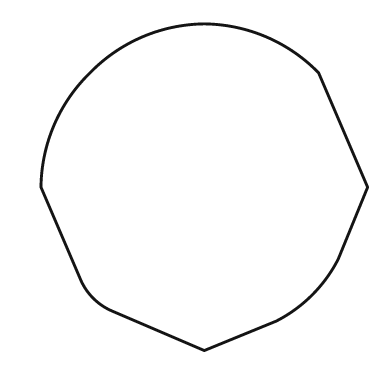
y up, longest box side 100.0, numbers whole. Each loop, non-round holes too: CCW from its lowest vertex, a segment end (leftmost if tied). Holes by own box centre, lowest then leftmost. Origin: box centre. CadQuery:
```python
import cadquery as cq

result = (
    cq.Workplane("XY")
    .moveTo(0.0, -50.0)
    .lineTo(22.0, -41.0)
    .threePointArc((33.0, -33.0), (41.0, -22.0))
    .lineTo(50.0, 0.0)
    .lineTo(35.0, 35.0)
    .threePointArc((19.0, 46.0), (0.0, 50.0))
    .threePointArc((-19.0, 46.0), (-35.0, 35.0))
    .threePointArc((-46.0, 19.0), (-50.0, 0.0))
    .lineTo(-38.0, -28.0)
    .threePointArc((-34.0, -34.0), (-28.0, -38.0))
    .close()
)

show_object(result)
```